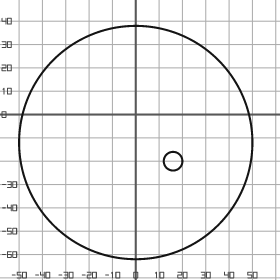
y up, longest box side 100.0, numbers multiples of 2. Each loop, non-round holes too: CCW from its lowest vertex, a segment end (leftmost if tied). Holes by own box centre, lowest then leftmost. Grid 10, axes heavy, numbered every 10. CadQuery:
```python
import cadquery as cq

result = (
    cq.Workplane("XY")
    .moveTo(0.0, -12.0)
    .circle(50.0)
    .moveTo(16.0, -20.0)
    .circle(4.0)
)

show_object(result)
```